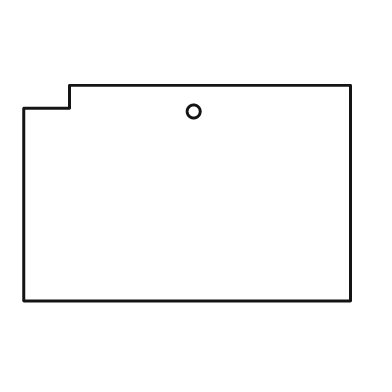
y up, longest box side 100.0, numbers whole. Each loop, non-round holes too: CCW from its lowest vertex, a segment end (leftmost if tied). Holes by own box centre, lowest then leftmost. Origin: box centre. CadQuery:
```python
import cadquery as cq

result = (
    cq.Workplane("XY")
    .moveTo(-50.0, -33.0)
    .lineTo(50.0, -33.0)
    .lineTo(50.0, 33.0)
    .lineTo(-36.0, 33.0)
    .lineTo(-36.0, 26.0)
    .lineTo(-50.0, 26.0)
    .close()
    .moveTo(2.0, 25.0)
    .circle(2.0)
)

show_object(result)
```